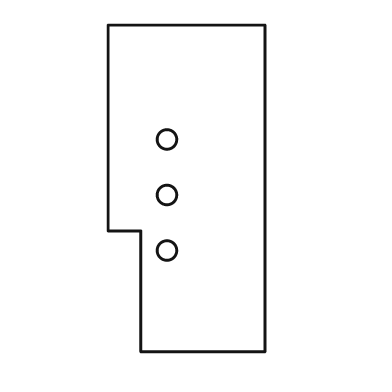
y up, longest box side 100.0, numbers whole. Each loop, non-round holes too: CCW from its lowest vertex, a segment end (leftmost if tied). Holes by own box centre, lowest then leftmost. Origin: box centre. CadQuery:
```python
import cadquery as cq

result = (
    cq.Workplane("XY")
    .moveTo(-14.0, -50.0)
    .lineTo(24.0, -50.0)
    .lineTo(24.0, 50.0)
    .lineTo(-24.0, 50.0)
    .lineTo(-24.0, -13.0)
    .lineTo(-14.0, -13.0)
    .close()
    .moveTo(-6.0, -19.0)
    .circle(3.0)
    .moveTo(-6.0, -2.0)
    .circle(3.0)
    .moveTo(-6.0, 15.0)
    .circle(3.0)
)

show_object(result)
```